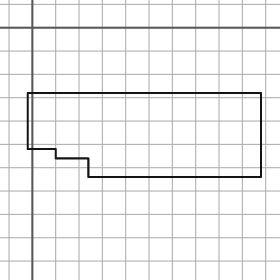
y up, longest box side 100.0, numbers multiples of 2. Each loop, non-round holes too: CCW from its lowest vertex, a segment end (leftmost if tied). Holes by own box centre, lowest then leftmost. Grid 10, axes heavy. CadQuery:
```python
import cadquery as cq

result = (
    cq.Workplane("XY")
    .moveTo(24.0, -64.0)
    .lineTo(98.0, -64.0)
    .lineTo(98.0, -28.0)
    .lineTo(-2.0, -28.0)
    .lineTo(-2.0, -52.0)
    .lineTo(10.0, -52.0)
    .lineTo(10.0, -56.0)
    .lineTo(24.0, -56.0)
    .close()
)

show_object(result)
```